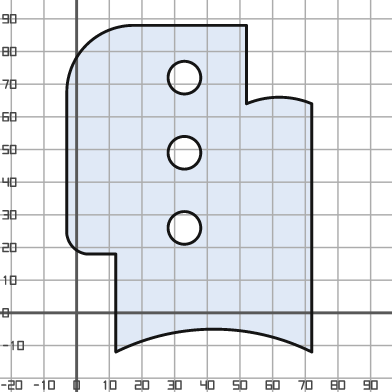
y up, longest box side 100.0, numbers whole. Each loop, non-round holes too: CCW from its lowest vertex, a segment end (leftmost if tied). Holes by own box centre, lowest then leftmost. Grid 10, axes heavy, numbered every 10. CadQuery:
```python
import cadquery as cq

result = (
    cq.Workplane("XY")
    .moveTo(12.0, -12.0)
    .threePointArc((42.0, -5.0), (72.0, -12.0))
    .lineTo(72.0, 64.0)
    .threePointArc((62.0, 66.0), (52.0, 64.0))
    .lineTo(52.0, 88.0)
    .lineTo(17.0, 88.0)
    .threePointArc((3.0, 82.0), (-3.0, 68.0))
    .lineTo(-3.0, 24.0)
    .threePointArc((-1.0, 20.0), (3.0, 18.0))
    .lineTo(12.0, 18.0)
    .close()
    .moveTo(33.0, 26.0)
    .circle(5.0)
    .moveTo(33.0, 49.0)
    .circle(5.0)
    .moveTo(33.0, 72.0)
    .circle(5.0)
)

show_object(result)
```